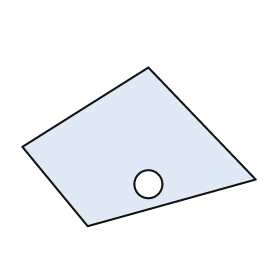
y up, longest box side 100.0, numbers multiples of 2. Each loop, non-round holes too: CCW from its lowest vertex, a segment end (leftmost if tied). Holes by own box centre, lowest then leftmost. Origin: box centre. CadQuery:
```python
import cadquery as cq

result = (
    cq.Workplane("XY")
    .moveTo(-22.0, -34.0)
    .lineTo(50.0, -14.0)
    .lineTo(4.0, 34.0)
    .lineTo(-50.0, 0.0)
    .close()
    .moveTo(4.0, -16.0)
    .circle(6.0)
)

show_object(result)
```